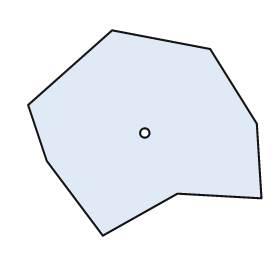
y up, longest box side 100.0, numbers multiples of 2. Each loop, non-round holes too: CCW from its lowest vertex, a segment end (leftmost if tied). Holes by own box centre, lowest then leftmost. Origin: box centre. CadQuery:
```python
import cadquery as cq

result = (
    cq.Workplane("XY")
    .moveTo(-18.0, -44.0)
    .lineTo(14.0, -26.0)
    .lineTo(50.0, -28.0)
    .lineTo(48.0, 4.0)
    .lineTo(28.0, 36.0)
    .lineTo(-14.0, 44.0)
    .lineTo(-50.0, 12.0)
    .lineTo(-42.0, -12.0)
    .close()
    .moveTo(0.0, 0.0)
    .circle(2.0)
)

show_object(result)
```